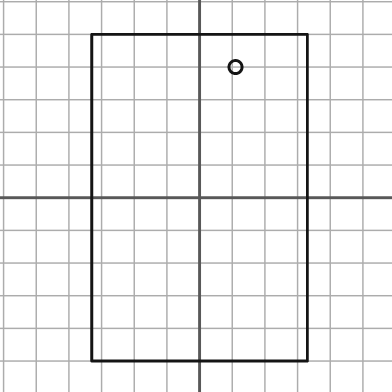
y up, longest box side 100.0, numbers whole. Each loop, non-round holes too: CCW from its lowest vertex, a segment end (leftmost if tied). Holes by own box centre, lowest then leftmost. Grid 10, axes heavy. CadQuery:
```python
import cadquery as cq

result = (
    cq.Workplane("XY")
    .moveTo(-33.0, -50.0)
    .lineTo(33.0, -50.0)
    .lineTo(33.0, 50.0)
    .lineTo(-33.0, 50.0)
    .close()
    .moveTo(11.0, 40.0)
    .circle(2.0)
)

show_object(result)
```